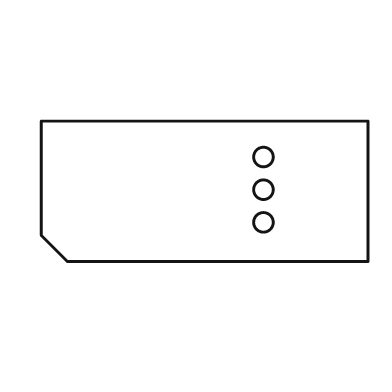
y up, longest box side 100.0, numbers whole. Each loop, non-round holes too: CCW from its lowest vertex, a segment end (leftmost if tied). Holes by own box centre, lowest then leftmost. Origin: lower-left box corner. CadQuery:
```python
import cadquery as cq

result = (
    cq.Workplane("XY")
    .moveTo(8.0, 0.0)
    .lineTo(100.0, 0.0)
    .lineTo(100.0, 43.0)
    .lineTo(0.0, 43.0)
    .lineTo(0.0, 8.0)
    .close()
    .moveTo(68.0, 12.0)
    .circle(3.0)
    .moveTo(68.0, 22.0)
    .circle(3.0)
    .moveTo(68.0, 32.0)
    .circle(3.0)
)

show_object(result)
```